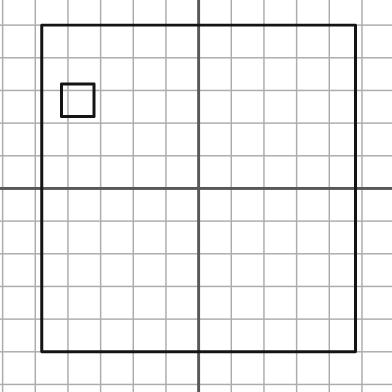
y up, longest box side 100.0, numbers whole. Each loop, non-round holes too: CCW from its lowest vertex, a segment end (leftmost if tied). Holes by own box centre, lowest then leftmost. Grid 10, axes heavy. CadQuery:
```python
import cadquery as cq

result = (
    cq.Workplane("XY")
    .moveTo(-48.0, -50.0)
    .lineTo(48.0, -50.0)
    .lineTo(48.0, 50.0)
    .lineTo(-48.0, 50.0)
    .close()
    .moveTo(-42.0, 22.0)
    .lineTo(-32.0, 22.0)
    .lineTo(-32.0, 32.0)
    .lineTo(-42.0, 32.0)
    .close()
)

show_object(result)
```